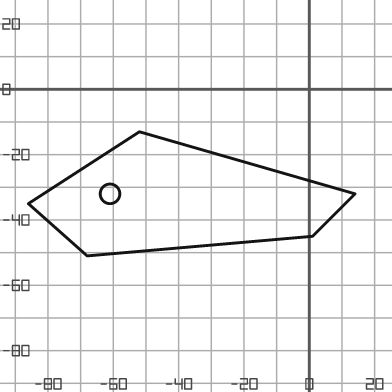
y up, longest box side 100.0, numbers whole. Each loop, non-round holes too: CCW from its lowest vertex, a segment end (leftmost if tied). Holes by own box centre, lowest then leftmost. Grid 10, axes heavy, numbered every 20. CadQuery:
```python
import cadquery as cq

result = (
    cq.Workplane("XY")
    .moveTo(-68.0, -51.0)
    .lineTo(1.0, -45.0)
    .lineTo(14.0, -32.0)
    .lineTo(-52.0, -13.0)
    .lineTo(-86.0, -35.0)
    .close()
    .moveTo(-61.0, -32.0)
    .circle(3.0)
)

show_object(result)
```